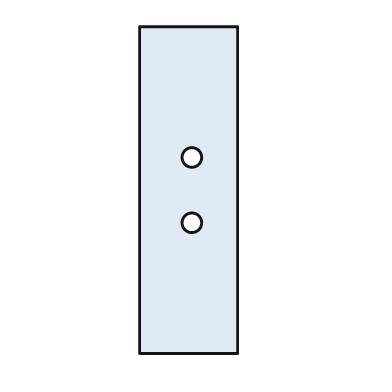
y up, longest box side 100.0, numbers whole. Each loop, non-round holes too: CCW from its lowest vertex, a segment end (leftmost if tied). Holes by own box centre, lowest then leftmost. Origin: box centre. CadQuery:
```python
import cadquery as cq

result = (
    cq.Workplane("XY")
    .moveTo(-15.0, -50.0)
    .lineTo(15.0, -50.0)
    .lineTo(15.0, 50.0)
    .lineTo(-15.0, 50.0)
    .close()
    .moveTo(1.0, -10.0)
    .circle(3.0)
    .moveTo(1.0, 10.0)
    .circle(3.0)
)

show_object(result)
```